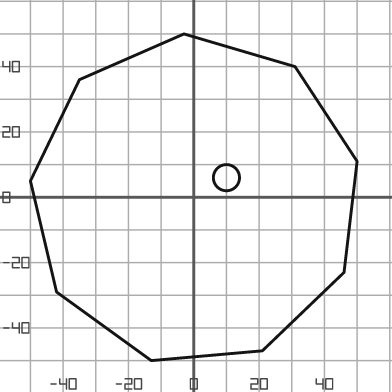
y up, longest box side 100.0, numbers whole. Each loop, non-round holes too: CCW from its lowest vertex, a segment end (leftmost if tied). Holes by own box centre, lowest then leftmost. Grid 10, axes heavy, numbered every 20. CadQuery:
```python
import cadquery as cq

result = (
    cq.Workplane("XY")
    .moveTo(-13.0, -50.0)
    .lineTo(21.0, -47.0)
    .lineTo(46.0, -23.0)
    .lineTo(50.0, 11.0)
    .lineTo(31.0, 40.0)
    .lineTo(-3.0, 50.0)
    .lineTo(-35.0, 36.0)
    .lineTo(-50.0, 5.0)
    .lineTo(-42.0, -29.0)
    .close()
    .moveTo(10.0, 6.0)
    .circle(4.0)
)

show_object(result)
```